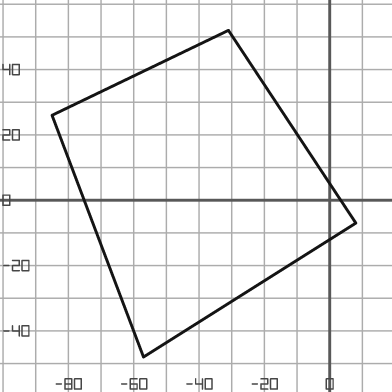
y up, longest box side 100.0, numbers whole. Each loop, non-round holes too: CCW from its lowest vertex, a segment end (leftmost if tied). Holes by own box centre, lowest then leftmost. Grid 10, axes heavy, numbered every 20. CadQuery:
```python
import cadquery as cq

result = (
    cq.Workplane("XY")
    .moveTo(-57.0, -48.0)
    .lineTo(8.0, -7.0)
    .lineTo(-31.0, 52.0)
    .lineTo(-85.0, 26.0)
    .close()
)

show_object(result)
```